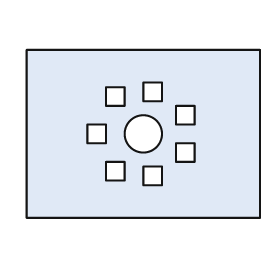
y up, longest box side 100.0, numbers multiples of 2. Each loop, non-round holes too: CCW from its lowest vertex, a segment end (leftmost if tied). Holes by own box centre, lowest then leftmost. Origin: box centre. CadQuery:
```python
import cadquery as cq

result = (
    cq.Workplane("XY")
    .moveTo(-50.0, -36.0)
    .lineTo(50.0, -36.0)
    .lineTo(50.0, 36.0)
    .lineTo(-50.0, 36.0)
    .close()
    .moveTo(0.0, -22.0)
    .lineTo(8.0, -22.0)
    .lineTo(8.0, -14.0)
    .lineTo(0.0, -14.0)
    .close()
    .moveTo(-16.0, -20.0)
    .lineTo(-8.0, -20.0)
    .lineTo(-8.0, -12.0)
    .lineTo(-16.0, -12.0)
    .close()
    .moveTo(14.0, -12.0)
    .lineTo(22.0, -12.0)
    .lineTo(22.0, -4.0)
    .lineTo(14.0, -4.0)
    .close()
    .moveTo(-24.0, -4.0)
    .lineTo(-16.0, -4.0)
    .lineTo(-16.0, 4.0)
    .lineTo(-24.0, 4.0)
    .close()
    .moveTo(0.0, 0.0)
    .circle(8.0)
    .moveTo(14.0, 4.0)
    .lineTo(22.0, 4.0)
    .lineTo(22.0, 12.0)
    .lineTo(14.0, 12.0)
    .close()
    .moveTo(-16.0, 12.0)
    .lineTo(-8.0, 12.0)
    .lineTo(-8.0, 20.0)
    .lineTo(-16.0, 20.0)
    .close()
    .moveTo(0.0, 14.0)
    .lineTo(8.0, 14.0)
    .lineTo(8.0, 22.0)
    .lineTo(0.0, 22.0)
    .close()
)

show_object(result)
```